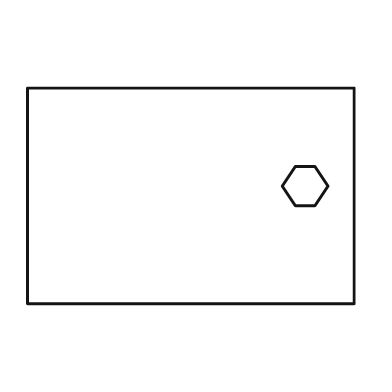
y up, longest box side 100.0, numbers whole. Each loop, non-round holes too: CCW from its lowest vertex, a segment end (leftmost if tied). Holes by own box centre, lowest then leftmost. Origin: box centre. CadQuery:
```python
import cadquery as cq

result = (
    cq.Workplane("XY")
    .moveTo(-50.0, -33.0)
    .lineTo(50.0, -33.0)
    .lineTo(50.0, 33.0)
    .lineTo(-50.0, 33.0)
    .close()
    .moveTo(32.0, -3.0)
    .lineTo(38.0, -3.0)
    .lineTo(42.0, 3.0)
    .lineTo(38.0, 9.0)
    .lineTo(32.0, 9.0)
    .lineTo(28.0, 3.0)
    .close()
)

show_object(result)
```